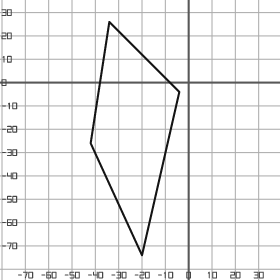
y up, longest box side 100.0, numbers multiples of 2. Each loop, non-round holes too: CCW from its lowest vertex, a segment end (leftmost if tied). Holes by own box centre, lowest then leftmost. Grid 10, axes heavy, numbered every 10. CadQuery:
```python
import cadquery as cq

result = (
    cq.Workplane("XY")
    .moveTo(-20.0, -74.0)
    .lineTo(-4.0, -4.0)
    .lineTo(-34.0, 26.0)
    .lineTo(-42.0, -26.0)
    .close()
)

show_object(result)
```